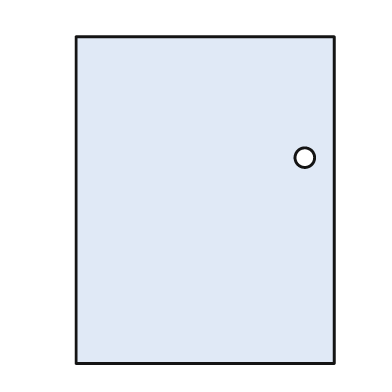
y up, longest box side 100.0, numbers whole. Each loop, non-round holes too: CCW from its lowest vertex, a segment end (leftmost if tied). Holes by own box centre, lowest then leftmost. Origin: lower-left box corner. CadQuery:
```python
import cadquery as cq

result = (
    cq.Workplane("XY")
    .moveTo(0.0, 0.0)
    .lineTo(79.0, 0.0)
    .lineTo(79.0, 100.0)
    .lineTo(0.0, 100.0)
    .close()
    .moveTo(70.0, 63.0)
    .circle(3.0)
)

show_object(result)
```